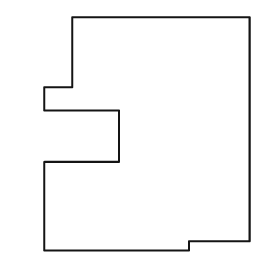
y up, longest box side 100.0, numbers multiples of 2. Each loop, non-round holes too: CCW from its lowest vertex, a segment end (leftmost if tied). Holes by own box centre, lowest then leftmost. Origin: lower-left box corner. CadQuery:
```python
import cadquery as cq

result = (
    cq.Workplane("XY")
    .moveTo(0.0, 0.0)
    .lineTo(62.0, 0.0)
    .lineTo(62.0, 4.0)
    .lineTo(88.0, 4.0)
    .lineTo(88.0, 100.0)
    .lineTo(12.0, 100.0)
    .lineTo(12.0, 70.0)
    .lineTo(0.0, 70.0)
    .lineTo(0.0, 60.0)
    .lineTo(32.0, 60.0)
    .lineTo(32.0, 38.0)
    .lineTo(0.0, 38.0)
    .close()
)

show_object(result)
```